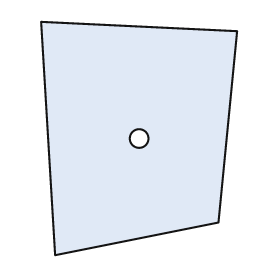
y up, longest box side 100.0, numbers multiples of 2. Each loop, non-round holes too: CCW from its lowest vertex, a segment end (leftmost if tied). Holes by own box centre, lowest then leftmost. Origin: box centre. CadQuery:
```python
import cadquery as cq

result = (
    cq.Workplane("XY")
    .moveTo(-36.0, -50.0)
    .lineTo(34.0, -36.0)
    .lineTo(42.0, 46.0)
    .lineTo(-42.0, 50.0)
    .close()
    .moveTo(0.0, 0.0)
    .circle(4.0)
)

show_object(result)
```